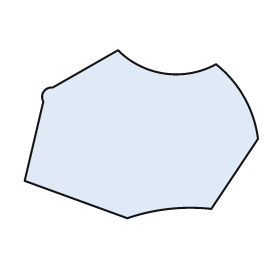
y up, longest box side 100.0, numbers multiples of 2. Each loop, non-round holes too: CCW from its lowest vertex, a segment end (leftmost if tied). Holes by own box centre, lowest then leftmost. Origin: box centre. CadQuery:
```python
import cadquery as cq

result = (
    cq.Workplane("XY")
    .moveTo(-6.0, -36.0)
    .threePointArc((12.0, -32.0), (30.0, -32.0))
    .lineTo(50.0, -2.0)
    .threePointArc((44.0, 16.0), (32.0, 30.0))
    .threePointArc((10.0, 26.0), (-10.0, 36.0))
    .lineTo(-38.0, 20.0)
    .threePointArc((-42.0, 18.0), (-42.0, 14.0))
    .lineTo(-50.0, -20.0)
    .close()
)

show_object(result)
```